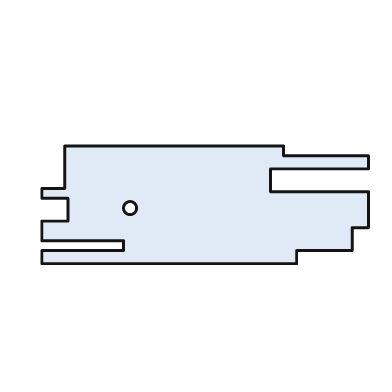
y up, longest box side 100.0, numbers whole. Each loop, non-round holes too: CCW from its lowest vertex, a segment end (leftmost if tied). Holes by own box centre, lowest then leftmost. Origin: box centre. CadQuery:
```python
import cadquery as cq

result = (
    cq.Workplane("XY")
    .moveTo(-50.0, -18.0)
    .lineTo(28.0, -18.0)
    .lineTo(28.0, -14.0)
    .lineTo(45.0, -14.0)
    .lineTo(45.0, -7.0)
    .lineTo(50.0, -7.0)
    .lineTo(50.0, 4.0)
    .lineTo(20.0, 4.0)
    .lineTo(20.0, 11.0)
    .lineTo(50.0, 11.0)
    .lineTo(50.0, 15.0)
    .lineTo(24.0, 15.0)
    .lineTo(24.0, 18.0)
    .lineTo(-43.0, 18.0)
    .lineTo(-43.0, 5.0)
    .lineTo(-50.0, 5.0)
    .lineTo(-50.0, 2.0)
    .lineTo(-42.0, 2.0)
    .lineTo(-42.0, -5.0)
    .lineTo(-50.0, -5.0)
    .lineTo(-50.0, -11.0)
    .lineTo(-25.0, -11.0)
    .lineTo(-25.0, -14.0)
    .lineTo(-50.0, -14.0)
    .close()
    .moveTo(-23.0, -1.0)
    .circle(2.0)
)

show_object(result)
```